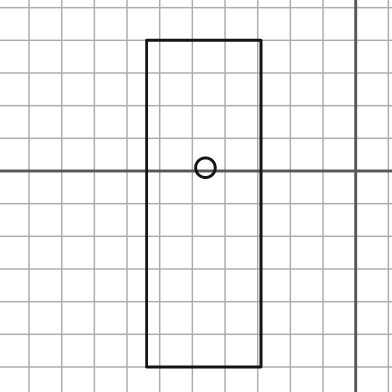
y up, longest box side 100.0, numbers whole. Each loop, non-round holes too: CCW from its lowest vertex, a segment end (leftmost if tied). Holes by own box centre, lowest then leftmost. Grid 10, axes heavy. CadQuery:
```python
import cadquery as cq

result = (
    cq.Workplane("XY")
    .moveTo(-64.0, -60.0)
    .lineTo(-29.0, -60.0)
    .lineTo(-29.0, 40.0)
    .lineTo(-64.0, 40.0)
    .close()
    .moveTo(-46.0, 1.0)
    .circle(3.0)
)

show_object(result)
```